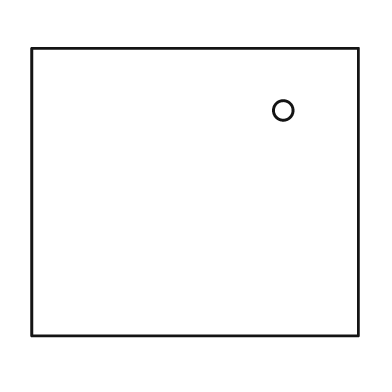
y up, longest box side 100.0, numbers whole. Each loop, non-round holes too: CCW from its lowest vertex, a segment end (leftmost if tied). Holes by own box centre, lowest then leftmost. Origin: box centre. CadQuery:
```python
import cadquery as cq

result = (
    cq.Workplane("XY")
    .moveTo(-50.0, -44.0)
    .lineTo(50.0, -44.0)
    .lineTo(50.0, 44.0)
    .lineTo(-50.0, 44.0)
    .close()
    .moveTo(27.0, 25.0)
    .circle(3.0)
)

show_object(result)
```